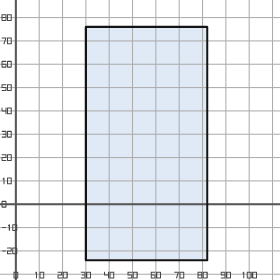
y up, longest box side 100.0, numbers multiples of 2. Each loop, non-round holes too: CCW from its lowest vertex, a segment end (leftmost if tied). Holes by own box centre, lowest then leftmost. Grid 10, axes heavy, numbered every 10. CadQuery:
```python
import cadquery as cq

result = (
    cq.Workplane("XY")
    .moveTo(30.0, -24.0)
    .lineTo(82.0, -24.0)
    .lineTo(82.0, 76.0)
    .lineTo(30.0, 76.0)
    .close()
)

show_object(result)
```